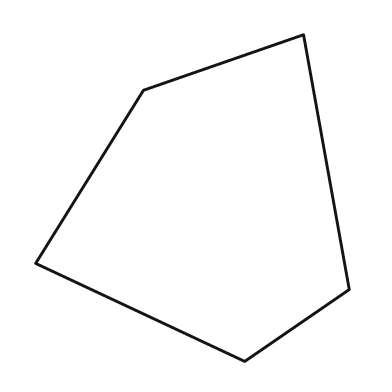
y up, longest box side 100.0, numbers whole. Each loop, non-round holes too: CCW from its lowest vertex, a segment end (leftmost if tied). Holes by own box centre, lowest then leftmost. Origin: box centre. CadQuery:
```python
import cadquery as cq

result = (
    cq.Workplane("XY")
    .moveTo(16.0, -50.0)
    .lineTo(48.0, -28.0)
    .lineTo(34.0, 50.0)
    .lineTo(-15.0, 33.0)
    .lineTo(-48.0, -20.0)
    .close()
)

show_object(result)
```